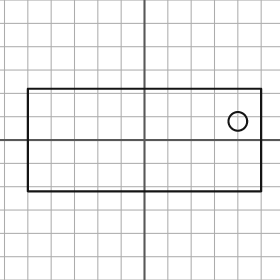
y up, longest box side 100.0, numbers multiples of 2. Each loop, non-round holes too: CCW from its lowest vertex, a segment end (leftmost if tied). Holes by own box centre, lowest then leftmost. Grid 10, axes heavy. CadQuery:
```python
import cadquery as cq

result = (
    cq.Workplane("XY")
    .moveTo(-50.0, -22.0)
    .lineTo(50.0, -22.0)
    .lineTo(50.0, 22.0)
    .lineTo(-50.0, 22.0)
    .close()
    .moveTo(40.0, 8.0)
    .circle(4.0)
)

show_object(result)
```